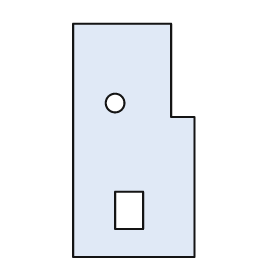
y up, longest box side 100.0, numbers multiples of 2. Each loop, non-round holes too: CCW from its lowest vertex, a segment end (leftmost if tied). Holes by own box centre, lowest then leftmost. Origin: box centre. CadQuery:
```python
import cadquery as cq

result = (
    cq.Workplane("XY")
    .moveTo(-26.0, -50.0)
    .lineTo(26.0, -50.0)
    .lineTo(26.0, 10.0)
    .lineTo(16.0, 10.0)
    .lineTo(16.0, 50.0)
    .lineTo(-26.0, 50.0)
    .close()
    .moveTo(-8.0, -38.0)
    .lineTo(4.0, -38.0)
    .lineTo(4.0, -22.0)
    .lineTo(-8.0, -22.0)
    .close()
    .moveTo(-8.0, 16.0)
    .circle(4.0)
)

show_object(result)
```